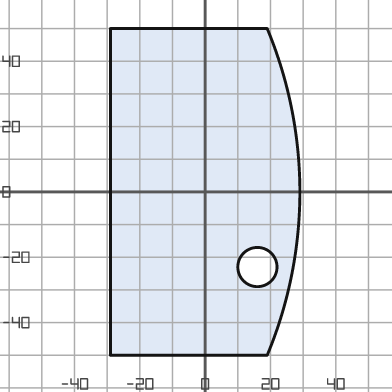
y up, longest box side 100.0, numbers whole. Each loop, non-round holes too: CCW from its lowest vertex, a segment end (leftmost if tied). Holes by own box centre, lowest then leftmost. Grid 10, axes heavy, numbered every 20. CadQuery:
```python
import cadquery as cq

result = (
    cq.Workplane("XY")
    .moveTo(-29.0, -50.0)
    .lineTo(19.0, -50.0)
    .threePointArc((29.0, 0.0), (19.0, 50.0))
    .lineTo(-29.0, 50.0)
    .close()
    .moveTo(16.0, -23.0)
    .circle(6.0)
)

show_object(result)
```